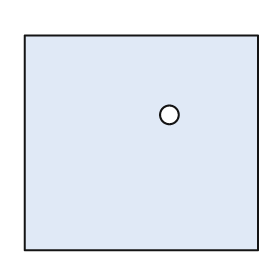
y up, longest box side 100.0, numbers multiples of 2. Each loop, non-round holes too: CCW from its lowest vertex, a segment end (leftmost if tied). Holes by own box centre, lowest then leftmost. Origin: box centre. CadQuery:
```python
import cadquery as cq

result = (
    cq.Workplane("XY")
    .moveTo(-50.0, -46.0)
    .lineTo(50.0, -46.0)
    .lineTo(50.0, 46.0)
    .lineTo(-50.0, 46.0)
    .close()
    .moveTo(12.0, 12.0)
    .circle(4.0)
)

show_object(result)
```